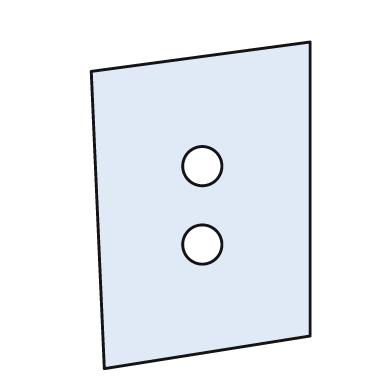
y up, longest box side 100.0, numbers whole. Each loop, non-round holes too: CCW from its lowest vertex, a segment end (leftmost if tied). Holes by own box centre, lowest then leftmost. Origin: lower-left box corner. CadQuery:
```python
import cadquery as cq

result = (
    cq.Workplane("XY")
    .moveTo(4.0, 0.0)
    .lineTo(67.0, 10.0)
    .lineTo(67.0, 100.0)
    .lineTo(0.0, 91.0)
    .close()
    .moveTo(34.0, 38.0)
    .circle(6.0)
    .moveTo(34.0, 62.0)
    .circle(6.0)
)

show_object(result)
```